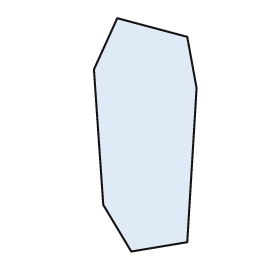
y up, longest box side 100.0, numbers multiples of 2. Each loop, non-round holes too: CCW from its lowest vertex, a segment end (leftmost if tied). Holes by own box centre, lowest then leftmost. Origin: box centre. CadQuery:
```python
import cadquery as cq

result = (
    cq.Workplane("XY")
    .moveTo(-6.0, -50.0)
    .lineTo(18.0, -46.0)
    .lineTo(22.0, 20.0)
    .lineTo(18.0, 42.0)
    .lineTo(-12.0, 50.0)
    .lineTo(-22.0, 28.0)
    .lineTo(-18.0, -30.0)
    .close()
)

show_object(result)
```